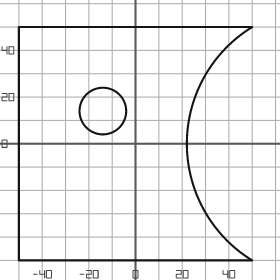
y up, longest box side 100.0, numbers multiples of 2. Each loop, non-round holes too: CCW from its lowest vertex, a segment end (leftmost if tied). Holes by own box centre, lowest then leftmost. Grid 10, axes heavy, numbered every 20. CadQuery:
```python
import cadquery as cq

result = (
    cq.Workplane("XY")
    .moveTo(-50.0, -50.0)
    .lineTo(50.0, -50.0)
    .threePointArc((22.0, 0.0), (50.0, 50.0))
    .lineTo(-50.0, 50.0)
    .close()
    .moveTo(-14.0, 14.0)
    .circle(10.0)
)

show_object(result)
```